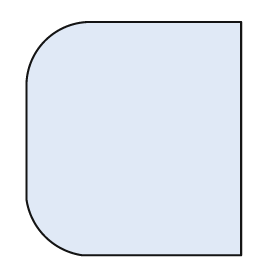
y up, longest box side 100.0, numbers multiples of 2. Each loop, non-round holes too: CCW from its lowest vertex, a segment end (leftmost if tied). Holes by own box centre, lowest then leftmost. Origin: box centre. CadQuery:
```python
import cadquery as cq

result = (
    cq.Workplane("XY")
    .moveTo(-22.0, -50.0)
    .lineTo(46.0, -50.0)
    .lineTo(46.0, 50.0)
    .lineTo(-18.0, 50.0)
    .threePointArc((-38.0, 42.0), (-46.0, 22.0))
    .lineTo(-46.0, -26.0)
    .threePointArc((-38.0, -42.0), (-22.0, -50.0))
    .close()
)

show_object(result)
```